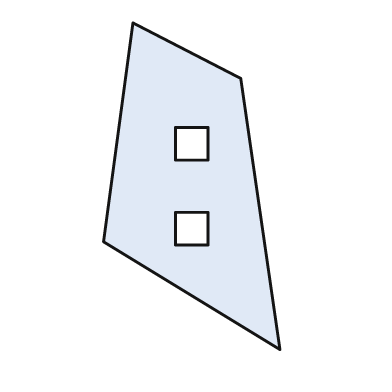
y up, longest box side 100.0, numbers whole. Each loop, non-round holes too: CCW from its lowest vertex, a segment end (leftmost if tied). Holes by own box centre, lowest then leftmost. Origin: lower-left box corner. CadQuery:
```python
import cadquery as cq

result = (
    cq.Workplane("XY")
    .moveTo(54.0, 0.0)
    .lineTo(42.0, 83.0)
    .lineTo(9.0, 100.0)
    .lineTo(0.0, 33.0)
    .close()
    .moveTo(22.0, 32.0)
    .lineTo(32.0, 32.0)
    .lineTo(32.0, 42.0)
    .lineTo(22.0, 42.0)
    .close()
    .moveTo(22.0, 58.0)
    .lineTo(32.0, 58.0)
    .lineTo(32.0, 68.0)
    .lineTo(22.0, 68.0)
    .close()
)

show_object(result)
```